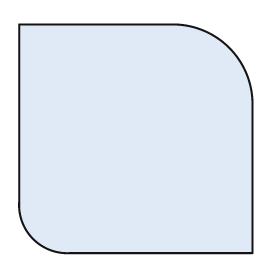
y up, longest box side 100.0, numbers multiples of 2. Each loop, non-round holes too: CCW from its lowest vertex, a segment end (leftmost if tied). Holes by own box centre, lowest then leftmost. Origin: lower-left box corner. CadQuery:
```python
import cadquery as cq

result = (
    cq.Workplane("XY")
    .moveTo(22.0, 0.0)
    .lineTo(100.0, 0.0)
    .lineTo(100.0, 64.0)
    .threePointArc((90.0, 88.0), (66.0, 98.0))
    .lineTo(0.0, 98.0)
    .lineTo(0.0, 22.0)
    .threePointArc((6.0, 6.0), (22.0, 0.0))
    .close()
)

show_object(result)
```